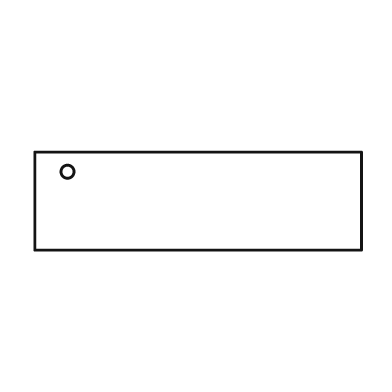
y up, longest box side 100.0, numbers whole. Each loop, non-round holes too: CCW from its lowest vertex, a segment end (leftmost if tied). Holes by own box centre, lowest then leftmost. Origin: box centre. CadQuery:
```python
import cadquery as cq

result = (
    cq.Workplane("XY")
    .moveTo(-50.0, -15.0)
    .lineTo(50.0, -15.0)
    .lineTo(50.0, 15.0)
    .lineTo(-50.0, 15.0)
    .close()
    .moveTo(-40.0, 9.0)
    .circle(2.0)
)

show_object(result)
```